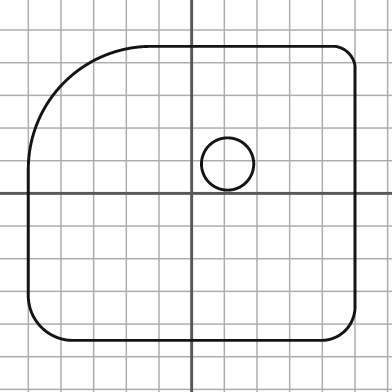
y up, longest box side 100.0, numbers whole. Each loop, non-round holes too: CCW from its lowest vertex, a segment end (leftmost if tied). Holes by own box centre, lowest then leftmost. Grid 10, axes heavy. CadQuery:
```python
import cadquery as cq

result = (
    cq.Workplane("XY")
    .moveTo(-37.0, -45.0)
    .lineTo(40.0, -45.0)
    .threePointArc((47.0, -42.0), (50.0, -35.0))
    .lineTo(50.0, 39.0)
    .threePointArc((48.0, 43.0), (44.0, 45.0))
    .lineTo(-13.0, 45.0)
    .threePointArc((-39.0, 34.0), (-50.0, 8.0))
    .lineTo(-50.0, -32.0)
    .threePointArc((-46.0, -41.0), (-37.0, -45.0))
    .close()
    .moveTo(11.0, 9.0)
    .circle(8.0)
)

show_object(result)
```